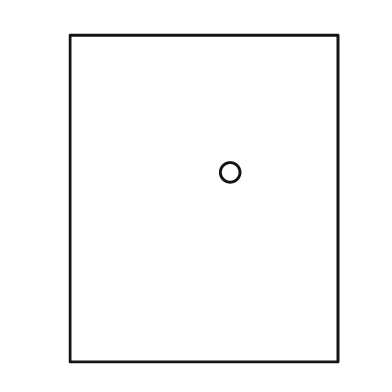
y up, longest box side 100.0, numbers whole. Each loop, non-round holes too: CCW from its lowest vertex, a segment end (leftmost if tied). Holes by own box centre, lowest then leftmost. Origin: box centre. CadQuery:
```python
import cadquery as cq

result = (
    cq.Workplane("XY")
    .moveTo(-41.0, -50.0)
    .lineTo(41.0, -50.0)
    .lineTo(41.0, 50.0)
    .lineTo(-41.0, 50.0)
    .close()
    .moveTo(8.0, 8.0)
    .circle(3.0)
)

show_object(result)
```